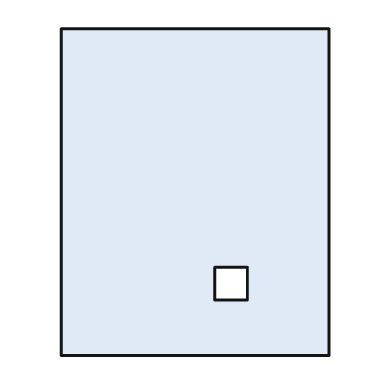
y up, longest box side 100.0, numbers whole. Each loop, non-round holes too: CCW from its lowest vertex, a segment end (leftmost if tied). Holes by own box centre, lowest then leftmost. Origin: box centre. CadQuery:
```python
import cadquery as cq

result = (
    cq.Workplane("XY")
    .moveTo(-41.0, -50.0)
    .lineTo(41.0, -50.0)
    .lineTo(41.0, 50.0)
    .lineTo(-41.0, 50.0)
    .close()
    .moveTo(6.0, -33.0)
    .lineTo(16.0, -33.0)
    .lineTo(16.0, -23.0)
    .lineTo(6.0, -23.0)
    .close()
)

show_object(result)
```